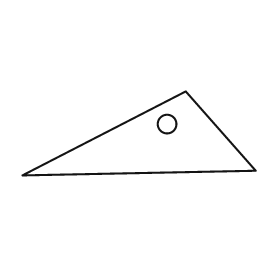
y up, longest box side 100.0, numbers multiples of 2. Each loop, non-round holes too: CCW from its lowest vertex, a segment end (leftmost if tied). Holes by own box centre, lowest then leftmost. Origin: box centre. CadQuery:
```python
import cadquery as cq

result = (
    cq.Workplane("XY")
    .moveTo(-50.0, -18.0)
    .lineTo(50.0, -16.0)
    .lineTo(20.0, 18.0)
    .close()
    .moveTo(12.0, 4.0)
    .circle(4.0)
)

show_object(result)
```